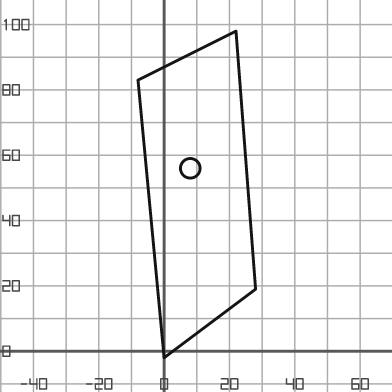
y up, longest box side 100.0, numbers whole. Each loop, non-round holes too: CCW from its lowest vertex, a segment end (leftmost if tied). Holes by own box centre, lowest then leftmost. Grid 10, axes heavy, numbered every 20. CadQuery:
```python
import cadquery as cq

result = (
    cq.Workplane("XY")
    .moveTo(0.0, -2.0)
    .lineTo(28.0, 19.0)
    .lineTo(22.0, 98.0)
    .lineTo(-8.0, 83.0)
    .close()
    .moveTo(8.0, 56.0)
    .circle(3.0)
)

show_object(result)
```